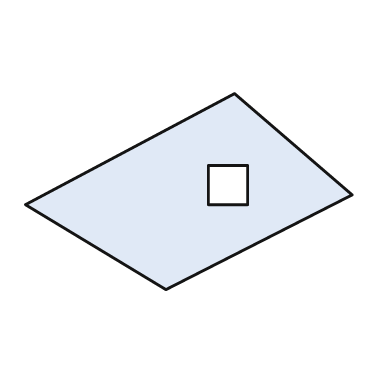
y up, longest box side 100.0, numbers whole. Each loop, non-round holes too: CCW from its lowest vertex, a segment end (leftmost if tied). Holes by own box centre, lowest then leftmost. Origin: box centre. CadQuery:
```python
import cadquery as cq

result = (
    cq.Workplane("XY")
    .moveTo(-7.0, -30.0)
    .lineTo(50.0, -1.0)
    .lineTo(14.0, 30.0)
    .lineTo(-50.0, -4.0)
    .close()
    .moveTo(6.0, -4.0)
    .lineTo(18.0, -4.0)
    .lineTo(18.0, 8.0)
    .lineTo(6.0, 8.0)
    .close()
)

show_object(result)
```